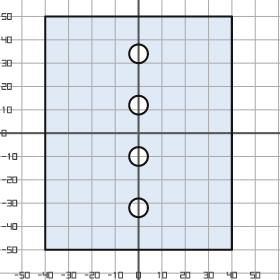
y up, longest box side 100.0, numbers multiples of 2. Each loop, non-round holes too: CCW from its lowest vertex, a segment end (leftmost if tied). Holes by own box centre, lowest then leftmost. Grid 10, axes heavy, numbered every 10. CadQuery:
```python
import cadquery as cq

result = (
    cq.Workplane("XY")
    .moveTo(-40.0, -50.0)
    .lineTo(40.0, -50.0)
    .lineTo(40.0, 50.0)
    .lineTo(-40.0, 50.0)
    .close()
    .moveTo(0.0, -32.0)
    .circle(4.0)
    .moveTo(0.0, -10.0)
    .circle(4.0)
    .moveTo(0.0, 12.0)
    .circle(4.0)
    .moveTo(0.0, 34.0)
    .circle(4.0)
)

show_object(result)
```